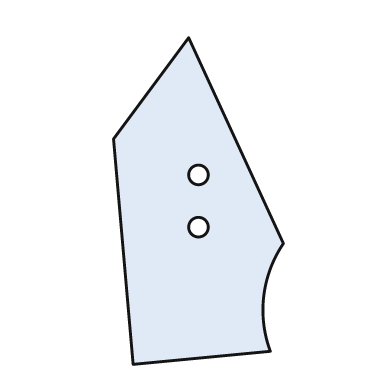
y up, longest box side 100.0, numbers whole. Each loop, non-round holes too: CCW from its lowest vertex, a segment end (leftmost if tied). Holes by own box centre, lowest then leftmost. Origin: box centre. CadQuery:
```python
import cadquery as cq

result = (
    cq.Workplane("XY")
    .moveTo(-20.0, -50.0)
    .lineTo(22.0, -46.0)
    .threePointArc((20.0, -29.0), (26.0, -13.0))
    .lineTo(-3.0, 50.0)
    .lineTo(-26.0, 19.0)
    .close()
    .moveTo(0.0, -8.0)
    .circle(3.0)
    .moveTo(0.0, 8.0)
    .circle(3.0)
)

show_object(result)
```